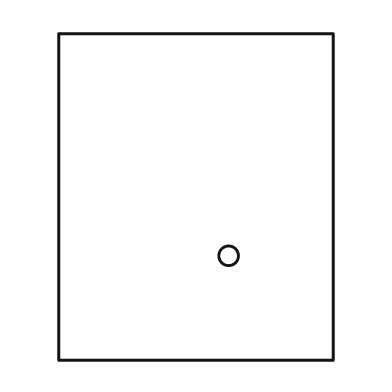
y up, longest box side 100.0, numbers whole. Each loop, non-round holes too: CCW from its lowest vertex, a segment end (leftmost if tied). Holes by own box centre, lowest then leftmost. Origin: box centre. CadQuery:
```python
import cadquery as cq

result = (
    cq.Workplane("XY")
    .moveTo(-42.0, -50.0)
    .lineTo(42.0, -50.0)
    .lineTo(42.0, 50.0)
    .lineTo(-42.0, 50.0)
    .close()
    .moveTo(10.0, -18.0)
    .circle(3.0)
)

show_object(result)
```